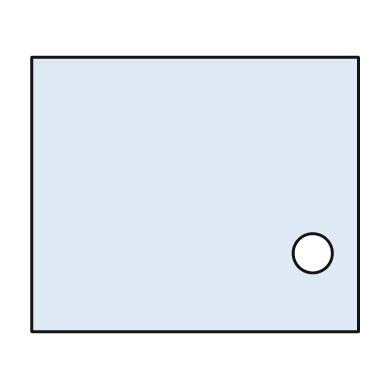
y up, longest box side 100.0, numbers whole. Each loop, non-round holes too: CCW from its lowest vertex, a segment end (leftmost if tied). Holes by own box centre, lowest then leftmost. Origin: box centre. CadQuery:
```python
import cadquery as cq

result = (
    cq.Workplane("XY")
    .moveTo(-50.0, -42.0)
    .lineTo(50.0, -42.0)
    .lineTo(50.0, 42.0)
    .lineTo(-50.0, 42.0)
    .close()
    .moveTo(36.0, -18.0)
    .circle(6.0)
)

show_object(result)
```